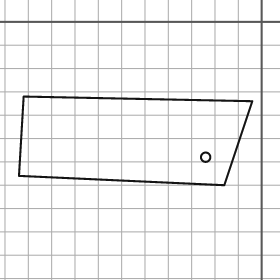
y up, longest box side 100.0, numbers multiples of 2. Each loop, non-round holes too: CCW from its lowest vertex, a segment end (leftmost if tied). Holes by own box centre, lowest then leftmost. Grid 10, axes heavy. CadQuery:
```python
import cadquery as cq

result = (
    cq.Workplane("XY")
    .moveTo(-16.0, -70.0)
    .lineTo(-4.0, -34.0)
    .lineTo(-102.0, -32.0)
    .lineTo(-104.0, -66.0)
    .close()
    .moveTo(-24.0, -58.0)
    .circle(2.0)
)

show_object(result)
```